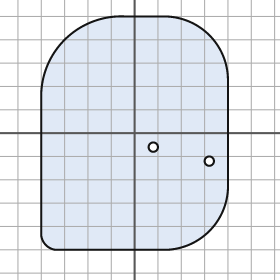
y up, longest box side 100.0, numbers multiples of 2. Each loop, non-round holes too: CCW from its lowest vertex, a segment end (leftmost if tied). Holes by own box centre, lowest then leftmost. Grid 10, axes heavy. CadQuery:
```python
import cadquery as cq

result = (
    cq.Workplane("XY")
    .moveTo(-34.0, -50.0)
    .lineTo(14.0, -50.0)
    .threePointArc((32.0, -42.0), (40.0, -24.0))
    .lineTo(40.0, 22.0)
    .threePointArc((32.0, 42.0), (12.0, 50.0))
    .lineTo(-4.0, 50.0)
    .threePointArc((-30.0, 40.0), (-40.0, 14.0))
    .lineTo(-40.0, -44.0)
    .threePointArc((-38.0, -48.0), (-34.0, -50.0))
    .close()
    .moveTo(32.0, -12.0)
    .circle(2.0)
    .moveTo(8.0, -6.0)
    .circle(2.0)
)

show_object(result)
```